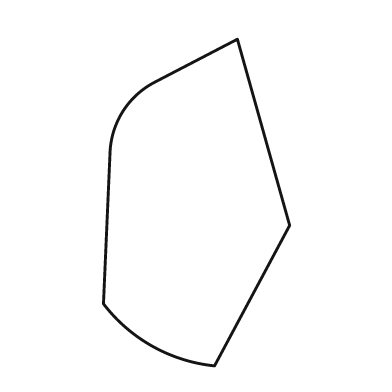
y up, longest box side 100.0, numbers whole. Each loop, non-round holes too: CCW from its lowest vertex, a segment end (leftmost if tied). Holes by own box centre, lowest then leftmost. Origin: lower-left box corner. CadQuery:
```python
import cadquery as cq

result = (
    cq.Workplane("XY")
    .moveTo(34.0, 0.0)
    .lineTo(57.0, 43.0)
    .lineTo(41.0, 100.0)
    .lineTo(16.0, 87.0)
    .threePointArc((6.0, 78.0), (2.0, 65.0))
    .lineTo(0.0, 19.0)
    .threePointArc((15.0, 6.0), (34.0, 0.0))
    .close()
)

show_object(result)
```